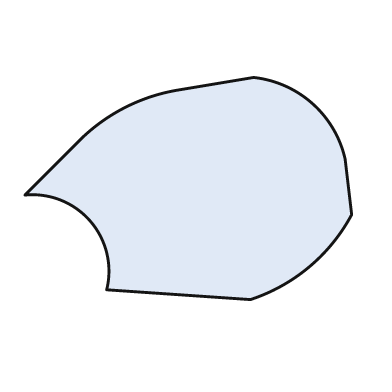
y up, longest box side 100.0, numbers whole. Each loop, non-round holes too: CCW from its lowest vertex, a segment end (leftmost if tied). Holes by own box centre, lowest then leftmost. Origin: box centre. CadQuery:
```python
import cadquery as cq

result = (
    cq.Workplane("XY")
    .moveTo(19.0, -34.0)
    .threePointArc((37.0, -24.0), (50.0, -8.0))
    .lineTo(48.0, 9.0)
    .threePointArc((38.0, 26.0), (20.0, 34.0))
    .lineTo(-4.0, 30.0)
    .threePointArc((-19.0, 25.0), (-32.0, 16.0))
    .lineTo(-50.0, -2.0)
    .threePointArc((-30.0, -10.0), (-25.0, -31.0))
    .close()
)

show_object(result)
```